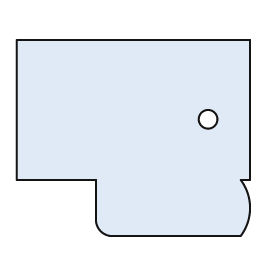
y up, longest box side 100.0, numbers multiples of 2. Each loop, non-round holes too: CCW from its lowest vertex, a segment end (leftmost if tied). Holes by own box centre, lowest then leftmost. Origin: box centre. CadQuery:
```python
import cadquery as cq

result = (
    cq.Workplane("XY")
    .moveTo(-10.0, -42.0)
    .lineTo(46.0, -42.0)
    .threePointArc((50.0, -30.0), (46.0, -18.0))
    .lineTo(50.0, -18.0)
    .lineTo(50.0, 42.0)
    .lineTo(-50.0, 42.0)
    .lineTo(-50.0, -18.0)
    .lineTo(-16.0, -18.0)
    .lineTo(-16.0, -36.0)
    .threePointArc((-14.0, -40.0), (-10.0, -42.0))
    .close()
    .moveTo(32.0, 8.0)
    .circle(4.0)
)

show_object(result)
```